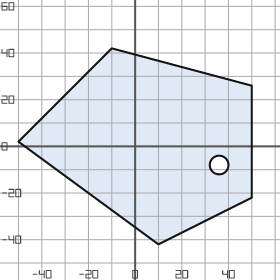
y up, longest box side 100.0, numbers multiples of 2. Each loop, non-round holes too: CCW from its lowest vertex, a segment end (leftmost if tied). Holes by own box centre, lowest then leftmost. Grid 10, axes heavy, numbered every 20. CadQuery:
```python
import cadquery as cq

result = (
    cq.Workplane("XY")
    .moveTo(10.0, -42.0)
    .lineTo(50.0, -22.0)
    .lineTo(50.0, 26.0)
    .lineTo(-10.0, 42.0)
    .lineTo(-50.0, 2.0)
    .close()
    .moveTo(36.0, -8.0)
    .circle(4.0)
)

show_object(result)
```